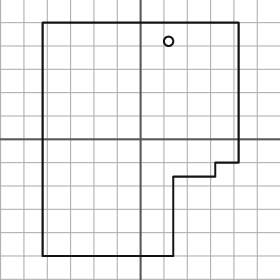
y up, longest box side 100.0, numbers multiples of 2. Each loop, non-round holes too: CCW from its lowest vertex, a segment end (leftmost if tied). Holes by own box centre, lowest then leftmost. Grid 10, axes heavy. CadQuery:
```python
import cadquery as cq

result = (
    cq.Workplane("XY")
    .moveTo(-42.0, -50.0)
    .lineTo(14.0, -50.0)
    .lineTo(14.0, -16.0)
    .lineTo(32.0, -16.0)
    .lineTo(32.0, -10.0)
    .lineTo(42.0, -10.0)
    .lineTo(42.0, 50.0)
    .lineTo(-42.0, 50.0)
    .close()
    .moveTo(12.0, 42.0)
    .circle(2.0)
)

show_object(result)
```